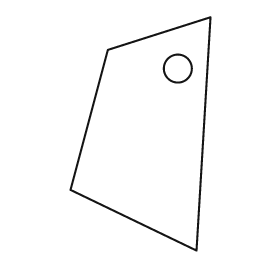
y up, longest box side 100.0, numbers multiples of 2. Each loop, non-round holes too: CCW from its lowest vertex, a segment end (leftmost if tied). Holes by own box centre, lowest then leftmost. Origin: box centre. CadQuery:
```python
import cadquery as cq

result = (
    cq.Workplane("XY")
    .moveTo(24.0, -50.0)
    .lineTo(30.0, 50.0)
    .lineTo(-14.0, 36.0)
    .lineTo(-30.0, -24.0)
    .close()
    .moveTo(16.0, 28.0)
    .circle(6.0)
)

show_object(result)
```